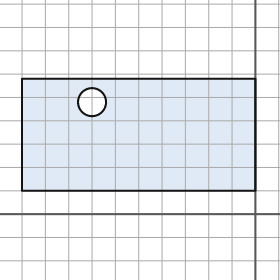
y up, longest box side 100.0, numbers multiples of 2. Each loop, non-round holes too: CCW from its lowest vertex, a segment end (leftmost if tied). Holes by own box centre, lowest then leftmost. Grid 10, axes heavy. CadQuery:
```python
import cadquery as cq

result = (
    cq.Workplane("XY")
    .moveTo(-100.0, 10.0)
    .lineTo(0.0, 10.0)
    .lineTo(0.0, 58.0)
    .lineTo(-100.0, 58.0)
    .close()
    .moveTo(-70.0, 48.0)
    .circle(6.0)
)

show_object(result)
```